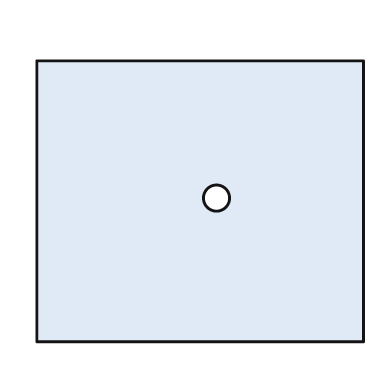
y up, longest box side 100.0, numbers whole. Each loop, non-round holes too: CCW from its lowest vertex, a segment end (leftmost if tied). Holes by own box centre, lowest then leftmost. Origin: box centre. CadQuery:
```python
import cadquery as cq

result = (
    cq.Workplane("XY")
    .moveTo(-50.0, -43.0)
    .lineTo(50.0, -43.0)
    .lineTo(50.0, 43.0)
    .lineTo(-50.0, 43.0)
    .close()
    .moveTo(5.0, 1.0)
    .circle(4.0)
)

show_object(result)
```